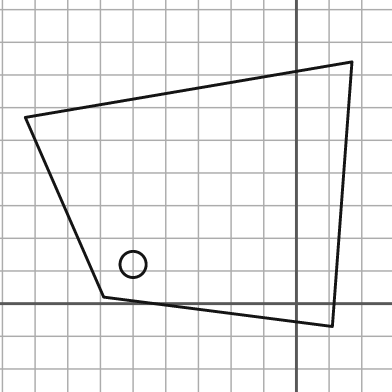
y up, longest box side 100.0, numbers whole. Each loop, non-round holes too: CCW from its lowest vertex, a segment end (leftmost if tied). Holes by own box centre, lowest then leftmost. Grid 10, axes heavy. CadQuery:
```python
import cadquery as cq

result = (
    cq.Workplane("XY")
    .moveTo(11.0, -7.0)
    .lineTo(17.0, 74.0)
    .lineTo(-83.0, 57.0)
    .lineTo(-59.0, 2.0)
    .close()
    .moveTo(-50.0, 12.0)
    .circle(4.0)
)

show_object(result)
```